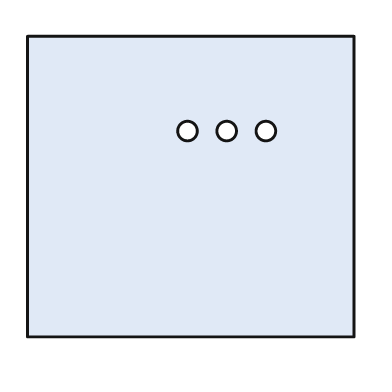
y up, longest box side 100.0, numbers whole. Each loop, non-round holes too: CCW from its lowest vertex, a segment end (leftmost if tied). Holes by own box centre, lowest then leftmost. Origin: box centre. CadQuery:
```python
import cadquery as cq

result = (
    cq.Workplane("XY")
    .moveTo(-50.0, -46.0)
    .lineTo(50.0, -46.0)
    .lineTo(50.0, 46.0)
    .lineTo(-50.0, 46.0)
    .close()
    .moveTo(-1.0, 17.0)
    .circle(3.0)
    .moveTo(11.0, 17.0)
    .circle(3.0)
    .moveTo(23.0, 17.0)
    .circle(3.0)
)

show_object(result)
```